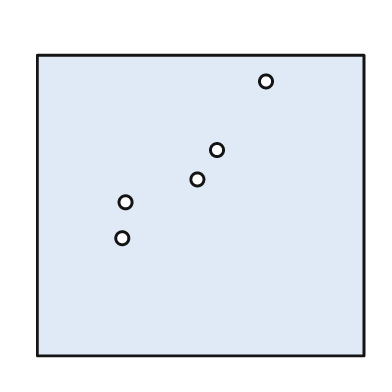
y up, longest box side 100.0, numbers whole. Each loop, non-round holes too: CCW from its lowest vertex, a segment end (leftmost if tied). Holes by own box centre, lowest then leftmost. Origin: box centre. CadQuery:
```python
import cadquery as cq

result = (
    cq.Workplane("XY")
    .moveTo(-50.0, -46.0)
    .lineTo(50.0, -46.0)
    .lineTo(50.0, 46.0)
    .lineTo(-50.0, 46.0)
    .close()
    .moveTo(-24.0, -10.0)
    .circle(2.0)
    .moveTo(-23.0, 1.0)
    .circle(2.0)
    .moveTo(-1.0, 8.0)
    .circle(2.0)
    .moveTo(5.0, 17.0)
    .circle(2.0)
    .moveTo(20.0, 38.0)
    .circle(2.0)
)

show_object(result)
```